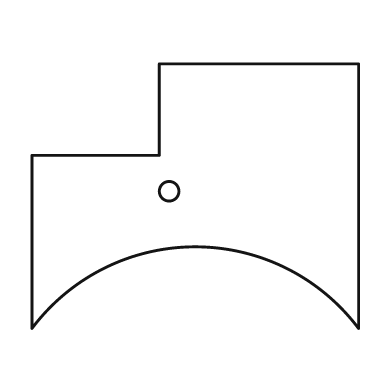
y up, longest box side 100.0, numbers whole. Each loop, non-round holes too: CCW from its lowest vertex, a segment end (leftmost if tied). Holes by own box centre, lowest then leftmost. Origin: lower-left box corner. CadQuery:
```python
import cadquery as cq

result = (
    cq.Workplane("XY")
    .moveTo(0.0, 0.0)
    .threePointArc((50.0, 25.0), (100.0, 0.0))
    .lineTo(100.0, 81.0)
    .lineTo(39.0, 81.0)
    .lineTo(39.0, 53.0)
    .lineTo(0.0, 53.0)
    .close()
    .moveTo(42.0, 42.0)
    .circle(3.0)
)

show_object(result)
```